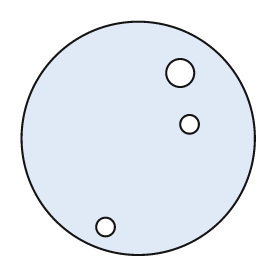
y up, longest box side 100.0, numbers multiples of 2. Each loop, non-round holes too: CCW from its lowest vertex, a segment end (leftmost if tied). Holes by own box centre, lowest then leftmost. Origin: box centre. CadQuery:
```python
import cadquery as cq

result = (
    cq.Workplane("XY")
    .moveTo(0.0, 0.0)
    .circle(50.0)
    .moveTo(-14.0, -38.0)
    .circle(4.0)
    .moveTo(22.0, 6.0)
    .circle(4.0)
    .moveTo(18.0, 28.0)
    .circle(6.0)
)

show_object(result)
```